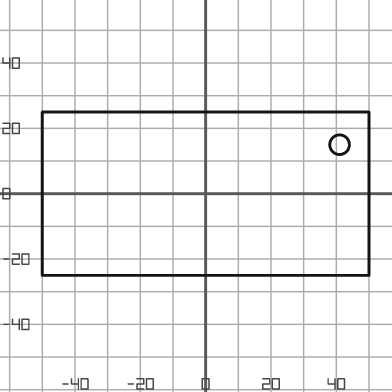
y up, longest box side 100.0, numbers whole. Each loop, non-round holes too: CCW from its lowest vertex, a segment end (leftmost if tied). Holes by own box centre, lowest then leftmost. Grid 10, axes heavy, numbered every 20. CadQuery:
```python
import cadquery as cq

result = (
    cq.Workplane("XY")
    .moveTo(-50.0, -25.0)
    .lineTo(50.0, -25.0)
    .lineTo(50.0, 25.0)
    .lineTo(-50.0, 25.0)
    .close()
    .moveTo(41.0, 15.0)
    .circle(3.0)
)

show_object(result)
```